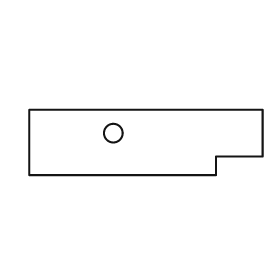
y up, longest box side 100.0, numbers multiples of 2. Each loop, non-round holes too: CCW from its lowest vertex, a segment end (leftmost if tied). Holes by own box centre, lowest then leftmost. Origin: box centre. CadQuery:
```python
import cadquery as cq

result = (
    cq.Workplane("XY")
    .moveTo(-50.0, -14.0)
    .lineTo(30.0, -14.0)
    .lineTo(30.0, -6.0)
    .lineTo(50.0, -6.0)
    .lineTo(50.0, 14.0)
    .lineTo(-50.0, 14.0)
    .close()
    .moveTo(-14.0, 4.0)
    .circle(4.0)
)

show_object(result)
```